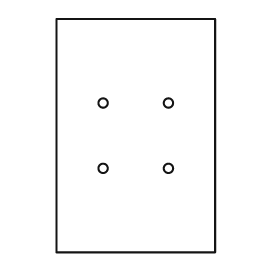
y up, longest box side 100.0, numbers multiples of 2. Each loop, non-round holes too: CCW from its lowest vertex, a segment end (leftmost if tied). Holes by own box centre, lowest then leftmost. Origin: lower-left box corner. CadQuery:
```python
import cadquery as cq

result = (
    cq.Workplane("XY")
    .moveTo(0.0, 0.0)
    .lineTo(68.0, 0.0)
    .lineTo(68.0, 100.0)
    .lineTo(0.0, 100.0)
    .close()
    .moveTo(20.0, 36.0)
    .circle(2.0)
    .moveTo(48.0, 36.0)
    .circle(2.0)
    .moveTo(20.0, 64.0)
    .circle(2.0)
    .moveTo(48.0, 64.0)
    .circle(2.0)
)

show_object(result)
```